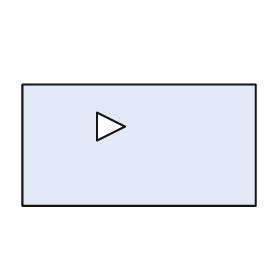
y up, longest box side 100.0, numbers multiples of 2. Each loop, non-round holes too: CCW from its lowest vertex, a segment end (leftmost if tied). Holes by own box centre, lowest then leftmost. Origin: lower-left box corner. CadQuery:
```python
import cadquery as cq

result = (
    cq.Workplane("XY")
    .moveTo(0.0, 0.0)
    .lineTo(100.0, 0.0)
    .lineTo(100.0, 52.0)
    .lineTo(0.0, 52.0)
    .close()
    .moveTo(32.0, 28.0)
    .lineTo(44.0, 34.0)
    .lineTo(32.0, 40.0)
    .close()
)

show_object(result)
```